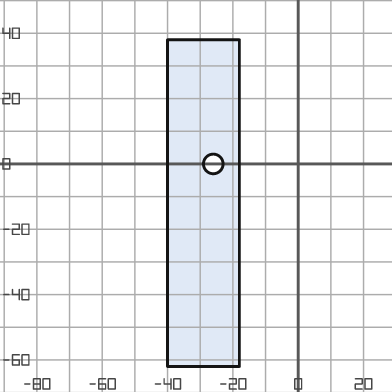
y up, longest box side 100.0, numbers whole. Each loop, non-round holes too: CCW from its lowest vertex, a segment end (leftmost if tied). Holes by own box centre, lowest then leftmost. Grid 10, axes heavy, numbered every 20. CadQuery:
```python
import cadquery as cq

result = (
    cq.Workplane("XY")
    .moveTo(-40.0, -62.0)
    .lineTo(-18.0, -62.0)
    .lineTo(-18.0, 38.0)
    .lineTo(-40.0, 38.0)
    .close()
    .moveTo(-26.0, 0.0)
    .circle(3.0)
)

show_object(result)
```